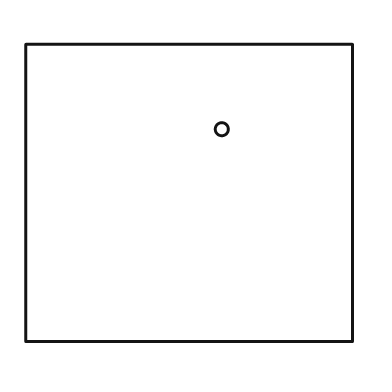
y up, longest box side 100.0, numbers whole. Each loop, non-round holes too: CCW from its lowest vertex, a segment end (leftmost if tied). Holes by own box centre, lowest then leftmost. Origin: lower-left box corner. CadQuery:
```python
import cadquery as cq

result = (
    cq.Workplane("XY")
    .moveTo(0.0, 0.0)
    .lineTo(100.0, 0.0)
    .lineTo(100.0, 91.0)
    .lineTo(0.0, 91.0)
    .close()
    .moveTo(60.0, 65.0)
    .circle(2.0)
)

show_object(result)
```